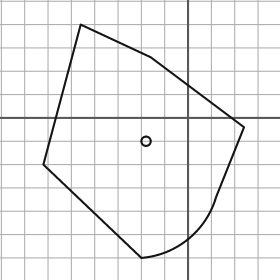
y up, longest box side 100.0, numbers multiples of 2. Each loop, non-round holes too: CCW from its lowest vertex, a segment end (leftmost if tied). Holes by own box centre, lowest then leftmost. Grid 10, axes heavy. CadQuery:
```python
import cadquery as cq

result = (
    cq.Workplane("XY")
    .moveTo(-20.0, -60.0)
    .threePointArc((0.0, -52.0), (12.0, -34.0))
    .lineTo(24.0, -4.0)
    .lineTo(-16.0, 26.0)
    .lineTo(-46.0, 40.0)
    .lineTo(-62.0, -20.0)
    .close()
    .moveTo(-18.0, -10.0)
    .circle(2.0)
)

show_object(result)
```